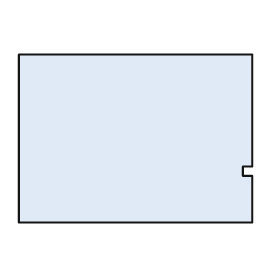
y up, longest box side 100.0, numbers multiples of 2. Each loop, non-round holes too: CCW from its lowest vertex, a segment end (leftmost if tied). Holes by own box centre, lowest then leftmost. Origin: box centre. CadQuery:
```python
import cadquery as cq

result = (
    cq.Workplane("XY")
    .moveTo(-50.0, -36.0)
    .lineTo(50.0, -36.0)
    .lineTo(50.0, -16.0)
    .lineTo(46.0, -16.0)
    .lineTo(46.0, -12.0)
    .lineTo(50.0, -12.0)
    .lineTo(50.0, 36.0)
    .lineTo(-50.0, 36.0)
    .close()
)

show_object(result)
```